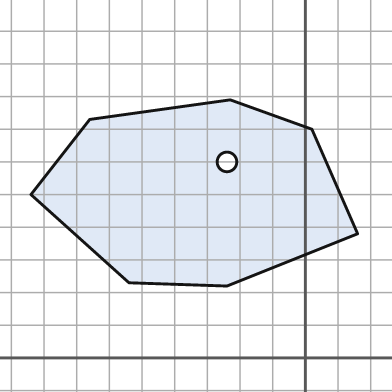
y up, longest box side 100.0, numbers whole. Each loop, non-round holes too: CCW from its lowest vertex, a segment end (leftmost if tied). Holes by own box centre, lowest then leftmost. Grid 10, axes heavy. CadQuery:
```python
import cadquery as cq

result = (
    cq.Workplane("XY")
    .moveTo(-24.0, 22.0)
    .lineTo(16.0, 38.0)
    .lineTo(2.0, 70.0)
    .lineTo(-23.0, 79.0)
    .lineTo(-66.0, 73.0)
    .lineTo(-84.0, 50.0)
    .lineTo(-54.0, 23.0)
    .close()
    .moveTo(-24.0, 60.0)
    .circle(3.0)
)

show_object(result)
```